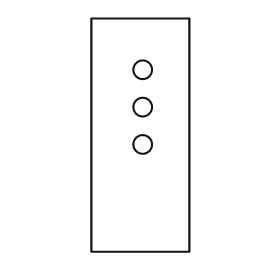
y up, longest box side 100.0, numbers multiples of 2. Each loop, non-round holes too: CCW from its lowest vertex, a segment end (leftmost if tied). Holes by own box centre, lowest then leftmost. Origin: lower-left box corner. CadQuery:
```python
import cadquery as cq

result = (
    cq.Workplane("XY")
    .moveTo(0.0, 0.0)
    .lineTo(42.0, 0.0)
    .lineTo(42.0, 100.0)
    .lineTo(0.0, 100.0)
    .close()
    .moveTo(22.0, 46.0)
    .circle(4.0)
    .moveTo(22.0, 62.0)
    .circle(4.0)
    .moveTo(22.0, 78.0)
    .circle(4.0)
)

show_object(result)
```